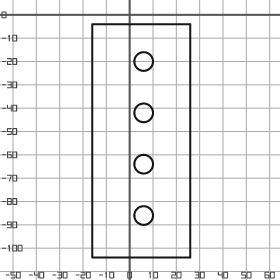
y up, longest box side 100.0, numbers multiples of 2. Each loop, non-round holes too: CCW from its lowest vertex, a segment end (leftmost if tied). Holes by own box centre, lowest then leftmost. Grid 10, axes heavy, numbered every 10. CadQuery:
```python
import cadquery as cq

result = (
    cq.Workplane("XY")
    .moveTo(-16.0, -104.0)
    .lineTo(26.0, -104.0)
    .lineTo(26.0, -4.0)
    .lineTo(-16.0, -4.0)
    .close()
    .moveTo(6.0, -86.0)
    .circle(4.0)
    .moveTo(6.0, -64.0)
    .circle(4.0)
    .moveTo(6.0, -42.0)
    .circle(4.0)
    .moveTo(6.0, -20.0)
    .circle(4.0)
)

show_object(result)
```